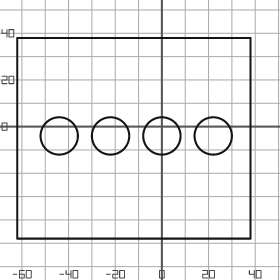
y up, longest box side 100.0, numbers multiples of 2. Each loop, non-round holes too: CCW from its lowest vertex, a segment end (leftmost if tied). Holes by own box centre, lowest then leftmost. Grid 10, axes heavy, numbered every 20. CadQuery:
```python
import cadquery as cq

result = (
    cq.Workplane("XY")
    .moveTo(-62.0, -48.0)
    .lineTo(38.0, -48.0)
    .lineTo(38.0, 38.0)
    .lineTo(-62.0, 38.0)
    .close()
    .moveTo(-44.0, -4.0)
    .circle(8.0)
    .moveTo(-22.0, -4.0)
    .circle(8.0)
    .moveTo(0.0, -4.0)
    .circle(8.0)
    .moveTo(22.0, -4.0)
    .circle(8.0)
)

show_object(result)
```